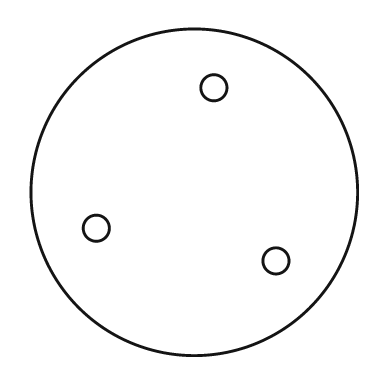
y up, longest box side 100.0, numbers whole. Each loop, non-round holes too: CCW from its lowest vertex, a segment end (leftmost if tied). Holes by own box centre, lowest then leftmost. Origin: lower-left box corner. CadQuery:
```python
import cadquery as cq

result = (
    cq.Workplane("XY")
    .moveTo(50.0, 50.0)
    .circle(50.0)
    .moveTo(75.0, 29.0)
    .circle(4.0)
    .moveTo(20.0, 39.0)
    .circle(4.0)
    .moveTo(56.0, 82.0)
    .circle(4.0)
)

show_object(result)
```